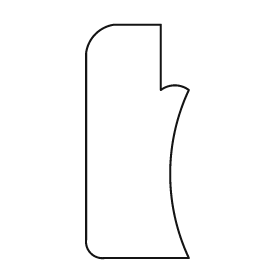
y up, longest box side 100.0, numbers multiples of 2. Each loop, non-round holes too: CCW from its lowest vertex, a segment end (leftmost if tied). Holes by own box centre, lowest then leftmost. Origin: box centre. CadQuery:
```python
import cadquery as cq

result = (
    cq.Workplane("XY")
    .moveTo(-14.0, -50.0)
    .lineTo(22.0, -50.0)
    .threePointArc((14.0, -14.0), (22.0, 22.0))
    .threePointArc((16.0, 24.0), (10.0, 22.0))
    .lineTo(10.0, 50.0)
    .lineTo(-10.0, 50.0)
    .threePointArc((-18.0, 46.0), (-22.0, 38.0))
    .lineTo(-22.0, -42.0)
    .threePointArc((-20.0, -48.0), (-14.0, -50.0))
    .close()
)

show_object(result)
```